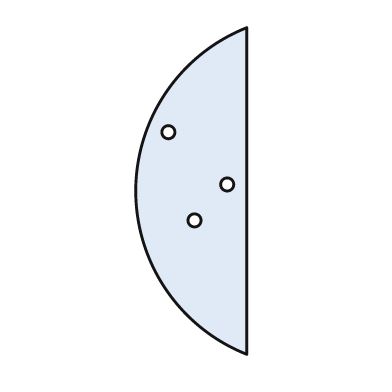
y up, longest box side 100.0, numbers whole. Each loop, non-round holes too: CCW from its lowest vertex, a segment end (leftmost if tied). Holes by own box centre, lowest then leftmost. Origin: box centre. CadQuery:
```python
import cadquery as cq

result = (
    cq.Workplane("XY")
    .moveTo(17.0, -50.0)
    .lineTo(17.0, 50.0)
    .threePointArc((-17.0, 0.0), (17.0, -50.0))
    .close()
    .moveTo(1.0, -9.0)
    .circle(2.0)
    .moveTo(11.0, 2.0)
    .circle(2.0)
    .moveTo(-7.0, 18.0)
    .circle(2.0)
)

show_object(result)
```